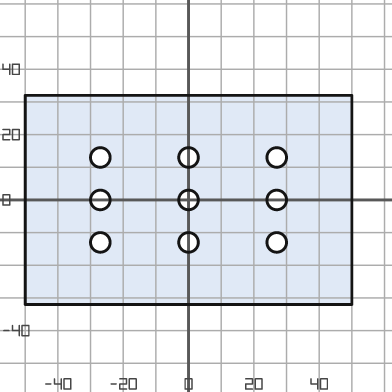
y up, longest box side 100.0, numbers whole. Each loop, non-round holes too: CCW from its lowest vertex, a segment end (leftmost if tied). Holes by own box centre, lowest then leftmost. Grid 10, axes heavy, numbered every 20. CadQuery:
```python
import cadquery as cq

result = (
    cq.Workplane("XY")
    .moveTo(-50.0, -32.0)
    .lineTo(50.0, -32.0)
    .lineTo(50.0, 32.0)
    .lineTo(-50.0, 32.0)
    .close()
    .moveTo(-27.0, -13.0)
    .circle(3.0)
    .moveTo(0.0, -13.0)
    .circle(3.0)
    .moveTo(27.0, -13.0)
    .circle(3.0)
    .moveTo(-27.0, 0.0)
    .circle(3.0)
    .moveTo(0.0, 0.0)
    .circle(3.0)
    .moveTo(27.0, 0.0)
    .circle(3.0)
    .moveTo(-27.0, 13.0)
    .circle(3.0)
    .moveTo(0.0, 13.0)
    .circle(3.0)
    .moveTo(27.0, 13.0)
    .circle(3.0)
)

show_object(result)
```